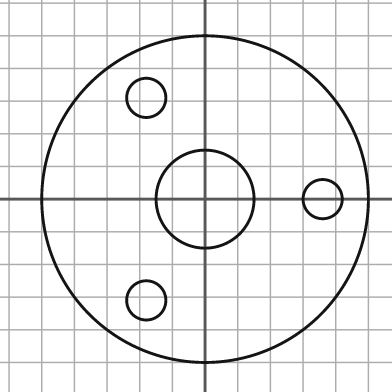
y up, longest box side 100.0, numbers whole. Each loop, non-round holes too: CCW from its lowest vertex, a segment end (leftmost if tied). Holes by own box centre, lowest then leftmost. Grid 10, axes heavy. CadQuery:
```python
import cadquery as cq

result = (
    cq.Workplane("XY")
    .moveTo(0.0, 0.0)
    .circle(50.0)
    .moveTo(-18.0, -31.0)
    .circle(6.0)
    .moveTo(0.0, 0.0)
    .circle(15.0)
    .moveTo(36.0, 0.0)
    .circle(6.0)
    .moveTo(-18.0, 31.0)
    .circle(6.0)
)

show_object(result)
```